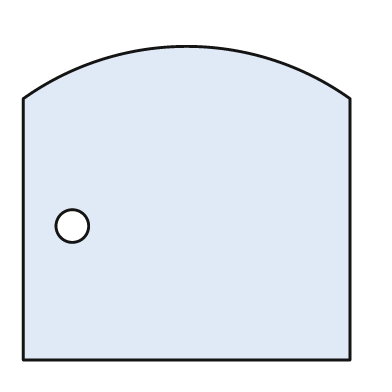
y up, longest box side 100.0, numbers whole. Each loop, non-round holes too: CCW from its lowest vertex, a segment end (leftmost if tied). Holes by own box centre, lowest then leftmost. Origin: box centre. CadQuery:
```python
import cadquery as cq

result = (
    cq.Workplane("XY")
    .moveTo(-50.0, -48.0)
    .lineTo(50.0, -48.0)
    .lineTo(50.0, 32.0)
    .threePointArc((0.0, 48.0), (-50.0, 32.0))
    .close()
    .moveTo(-35.0, -7.0)
    .circle(5.0)
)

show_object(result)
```